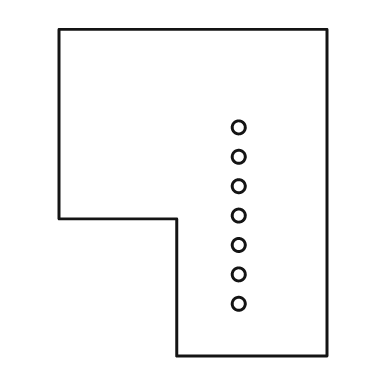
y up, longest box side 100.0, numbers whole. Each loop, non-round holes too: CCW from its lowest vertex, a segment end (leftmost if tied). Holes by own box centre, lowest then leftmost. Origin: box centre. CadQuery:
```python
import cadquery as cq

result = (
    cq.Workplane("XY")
    .moveTo(-5.0, -50.0)
    .lineTo(41.0, -50.0)
    .lineTo(41.0, 50.0)
    .lineTo(-41.0, 50.0)
    .lineTo(-41.0, -8.0)
    .lineTo(-5.0, -8.0)
    .close()
    .moveTo(14.0, -34.0)
    .circle(2.0)
    .moveTo(14.0, -25.0)
    .circle(2.0)
    .moveTo(14.0, -16.0)
    .circle(2.0)
    .moveTo(14.0, -7.0)
    .circle(2.0)
    .moveTo(14.0, 2.0)
    .circle(2.0)
    .moveTo(14.0, 11.0)
    .circle(2.0)
    .moveTo(14.0, 20.0)
    .circle(2.0)
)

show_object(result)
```